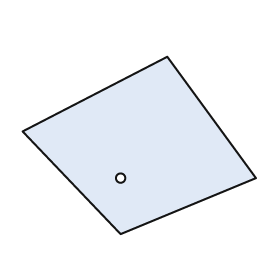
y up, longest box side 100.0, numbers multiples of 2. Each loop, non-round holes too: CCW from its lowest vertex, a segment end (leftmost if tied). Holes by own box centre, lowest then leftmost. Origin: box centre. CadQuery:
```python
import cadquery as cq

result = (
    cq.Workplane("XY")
    .moveTo(-8.0, -38.0)
    .lineTo(50.0, -14.0)
    .lineTo(12.0, 38.0)
    .lineTo(-50.0, 6.0)
    .close()
    .moveTo(-8.0, -14.0)
    .circle(2.0)
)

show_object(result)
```